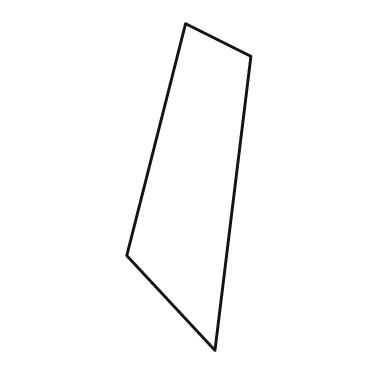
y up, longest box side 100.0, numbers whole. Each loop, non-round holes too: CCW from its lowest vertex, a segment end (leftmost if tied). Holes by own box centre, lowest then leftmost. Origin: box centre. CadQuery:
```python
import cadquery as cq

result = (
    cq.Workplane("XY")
    .moveTo(8.0, -50.0)
    .lineTo(19.0, 40.0)
    .lineTo(-1.0, 50.0)
    .lineTo(-19.0, -21.0)
    .close()
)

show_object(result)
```